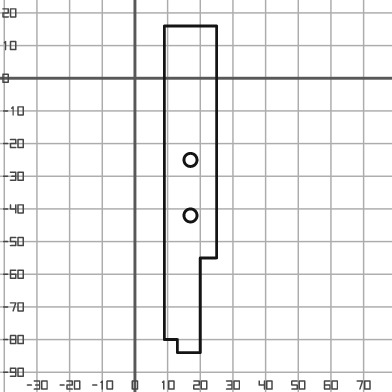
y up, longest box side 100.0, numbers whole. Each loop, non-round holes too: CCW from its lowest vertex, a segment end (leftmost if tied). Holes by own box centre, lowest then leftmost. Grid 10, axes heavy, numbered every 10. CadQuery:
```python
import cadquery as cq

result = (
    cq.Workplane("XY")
    .moveTo(13.0, -84.0)
    .lineTo(20.0, -84.0)
    .lineTo(20.0, -55.0)
    .lineTo(25.0, -55.0)
    .lineTo(25.0, 16.0)
    .lineTo(9.0, 16.0)
    .lineTo(9.0, -80.0)
    .lineTo(13.0, -80.0)
    .close()
    .moveTo(17.0, -42.0)
    .circle(2.0)
    .moveTo(17.0, -25.0)
    .circle(2.0)
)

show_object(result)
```